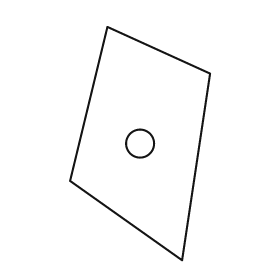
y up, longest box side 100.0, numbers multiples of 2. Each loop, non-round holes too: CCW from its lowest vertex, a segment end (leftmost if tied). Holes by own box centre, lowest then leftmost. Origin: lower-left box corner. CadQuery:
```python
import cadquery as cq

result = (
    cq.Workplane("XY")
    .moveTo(48.0, 0.0)
    .lineTo(60.0, 80.0)
    .lineTo(16.0, 100.0)
    .lineTo(0.0, 34.0)
    .close()
    .moveTo(30.0, 50.0)
    .circle(6.0)
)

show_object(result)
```